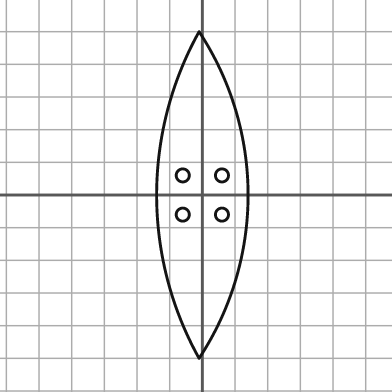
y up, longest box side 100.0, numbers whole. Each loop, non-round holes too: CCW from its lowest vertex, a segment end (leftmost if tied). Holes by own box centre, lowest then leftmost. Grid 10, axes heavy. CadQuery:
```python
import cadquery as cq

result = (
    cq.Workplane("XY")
    .moveTo(-1.0, -50.0)
    .threePointArc((14.0, 0.0), (-1.0, 50.0))
    .threePointArc((-14.0, 0.0), (-1.0, -50.0))
    .close()
    .moveTo(-6.0, -6.0)
    .circle(2.0)
    .moveTo(6.0, -6.0)
    .circle(2.0)
    .moveTo(-6.0, 6.0)
    .circle(2.0)
    .moveTo(6.0, 6.0)
    .circle(2.0)
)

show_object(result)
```